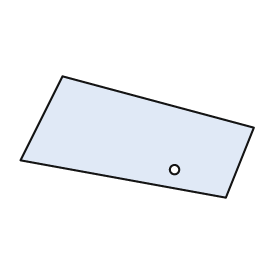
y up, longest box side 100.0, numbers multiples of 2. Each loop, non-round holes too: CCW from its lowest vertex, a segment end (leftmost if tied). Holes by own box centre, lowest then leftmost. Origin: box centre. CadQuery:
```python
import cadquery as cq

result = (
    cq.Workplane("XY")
    .moveTo(38.0, -26.0)
    .lineTo(50.0, 4.0)
    .lineTo(-32.0, 26.0)
    .lineTo(-50.0, -10.0)
    .close()
    .moveTo(16.0, -14.0)
    .circle(2.0)
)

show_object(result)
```